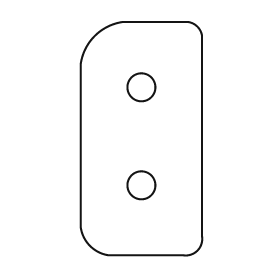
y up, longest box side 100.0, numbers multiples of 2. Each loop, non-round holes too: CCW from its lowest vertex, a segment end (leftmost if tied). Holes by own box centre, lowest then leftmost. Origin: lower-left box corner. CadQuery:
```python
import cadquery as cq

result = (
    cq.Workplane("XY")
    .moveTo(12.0, 0.0)
    .lineTo(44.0, 0.0)
    .threePointArc((50.0, 2.0), (52.0, 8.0))
    .lineTo(52.0, 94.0)
    .threePointArc((50.0, 98.0), (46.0, 100.0))
    .lineTo(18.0, 100.0)
    .threePointArc((6.0, 94.0), (0.0, 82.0))
    .lineTo(0.0, 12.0)
    .threePointArc((4.0, 4.0), (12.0, 0.0))
    .close()
    .moveTo(26.0, 30.0)
    .circle(6.0)
    .moveTo(26.0, 72.0)
    .circle(6.0)
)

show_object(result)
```